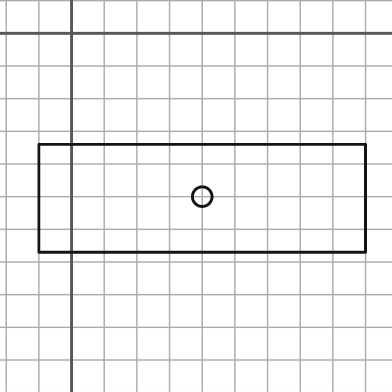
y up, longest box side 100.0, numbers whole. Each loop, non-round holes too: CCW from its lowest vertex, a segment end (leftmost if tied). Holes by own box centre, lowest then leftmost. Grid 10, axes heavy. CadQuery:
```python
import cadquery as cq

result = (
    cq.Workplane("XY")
    .moveTo(-10.0, -67.0)
    .lineTo(90.0, -67.0)
    .lineTo(90.0, -34.0)
    .lineTo(-10.0, -34.0)
    .close()
    .moveTo(40.0, -50.0)
    .circle(3.0)
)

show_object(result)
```